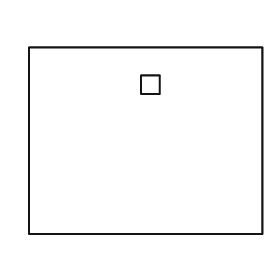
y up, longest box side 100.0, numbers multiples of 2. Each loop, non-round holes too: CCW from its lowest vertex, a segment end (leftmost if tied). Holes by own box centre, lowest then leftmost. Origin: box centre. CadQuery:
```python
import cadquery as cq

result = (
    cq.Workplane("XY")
    .moveTo(-50.0, -40.0)
    .lineTo(50.0, -40.0)
    .lineTo(50.0, 40.0)
    .lineTo(-50.0, 40.0)
    .close()
    .moveTo(-2.0, 20.0)
    .lineTo(6.0, 20.0)
    .lineTo(6.0, 28.0)
    .lineTo(-2.0, 28.0)
    .close()
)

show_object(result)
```